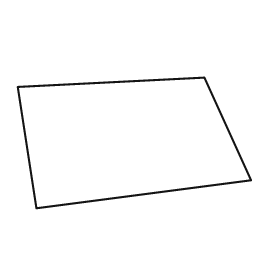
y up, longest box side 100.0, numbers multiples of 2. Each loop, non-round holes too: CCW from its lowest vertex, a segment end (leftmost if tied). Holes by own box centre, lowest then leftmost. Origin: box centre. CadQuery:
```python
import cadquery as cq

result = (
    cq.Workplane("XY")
    .moveTo(-42.0, -28.0)
    .lineTo(50.0, -16.0)
    .lineTo(30.0, 28.0)
    .lineTo(-50.0, 24.0)
    .close()
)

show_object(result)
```